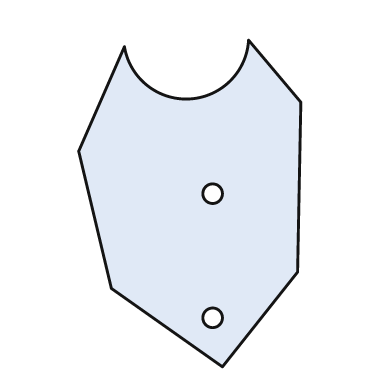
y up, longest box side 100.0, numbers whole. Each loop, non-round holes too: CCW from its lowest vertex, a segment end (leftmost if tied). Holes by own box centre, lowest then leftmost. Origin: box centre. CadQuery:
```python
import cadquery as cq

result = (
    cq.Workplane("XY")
    .moveTo(10.0, -50.0)
    .lineTo(33.0, -21.0)
    .lineTo(34.0, 31.0)
    .lineTo(18.0, 50.0)
    .threePointArc((0.0, 32.0), (-20.0, 48.0))
    .lineTo(-34.0, 16.0)
    .lineTo(-24.0, -26.0)
    .close()
    .moveTo(7.0, -35.0)
    .circle(3.0)
    .moveTo(7.0, 3.0)
    .circle(3.0)
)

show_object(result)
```